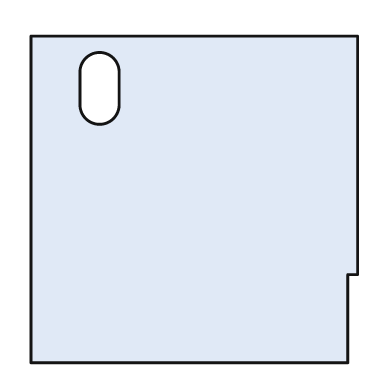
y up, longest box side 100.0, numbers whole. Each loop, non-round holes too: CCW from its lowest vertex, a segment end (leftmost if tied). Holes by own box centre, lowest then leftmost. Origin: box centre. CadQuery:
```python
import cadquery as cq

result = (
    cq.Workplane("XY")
    .moveTo(-50.0, -50.0)
    .lineTo(47.0, -50.0)
    .lineTo(47.0, -23.0)
    .lineTo(50.0, -23.0)
    .lineTo(50.0, 50.0)
    .lineTo(-50.0, 50.0)
    .close()
    .moveTo(-35.0, 29.0)
    .threePointArc((-29.0, 23.0), (-23.0, 29.0))
    .lineTo(-23.0, 39.0)
    .threePointArc((-29.0, 45.0), (-35.0, 39.0))
    .close()
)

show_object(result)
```